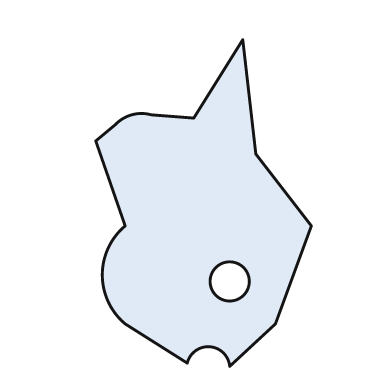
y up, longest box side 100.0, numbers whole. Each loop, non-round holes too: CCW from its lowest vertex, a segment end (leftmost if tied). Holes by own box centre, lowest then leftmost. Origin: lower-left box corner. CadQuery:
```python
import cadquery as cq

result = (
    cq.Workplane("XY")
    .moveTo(41.0, 0.0)
    .lineTo(55.0, 13.0)
    .lineTo(66.0, 43.0)
    .lineTo(49.0, 65.0)
    .lineTo(45.0, 100.0)
    .lineTo(30.0, 76.0)
    .lineTo(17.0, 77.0)
    .threePointArc((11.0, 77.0), (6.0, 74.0))
    .lineTo(0.0, 69.0)
    .lineTo(9.0, 43.0)
    .threePointArc((2.0, 28.0), (9.0, 13.0))
    .lineTo(28.0, 1.0)
    .threePointArc((35.0, 6.0), (41.0, 0.0))
    .close()
    .moveTo(41.0, 26.0)
    .circle(6.0)
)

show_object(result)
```